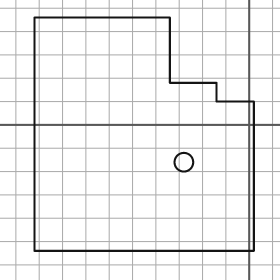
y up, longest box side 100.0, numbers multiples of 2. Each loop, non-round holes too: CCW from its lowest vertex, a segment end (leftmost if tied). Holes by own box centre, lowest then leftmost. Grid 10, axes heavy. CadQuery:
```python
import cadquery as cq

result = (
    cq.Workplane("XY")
    .moveTo(-92.0, -54.0)
    .lineTo(2.0, -54.0)
    .lineTo(2.0, 10.0)
    .lineTo(-14.0, 10.0)
    .lineTo(-14.0, 18.0)
    .lineTo(-34.0, 18.0)
    .lineTo(-34.0, 46.0)
    .lineTo(-92.0, 46.0)
    .close()
    .moveTo(-28.0, -16.0)
    .circle(4.0)
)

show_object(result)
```